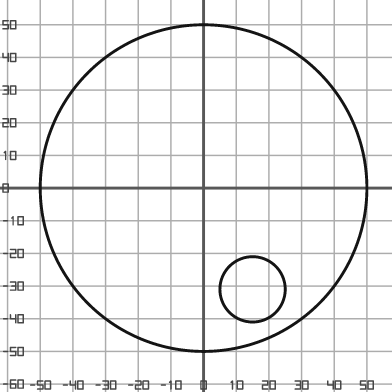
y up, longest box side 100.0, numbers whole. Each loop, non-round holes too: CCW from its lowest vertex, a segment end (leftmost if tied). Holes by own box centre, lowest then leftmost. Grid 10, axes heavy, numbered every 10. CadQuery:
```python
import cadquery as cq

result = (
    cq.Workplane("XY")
    .moveTo(0.0, 0.0)
    .circle(50.0)
    .moveTo(15.0, -31.0)
    .circle(10.0)
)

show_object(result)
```